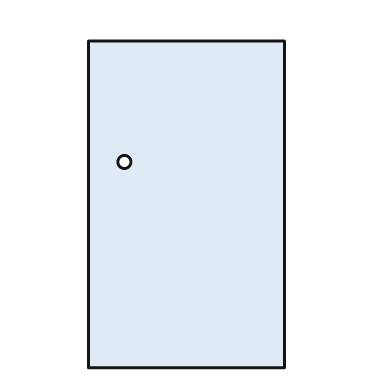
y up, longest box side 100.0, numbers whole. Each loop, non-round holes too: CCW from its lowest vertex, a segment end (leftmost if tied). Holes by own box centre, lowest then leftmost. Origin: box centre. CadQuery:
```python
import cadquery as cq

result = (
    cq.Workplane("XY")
    .moveTo(-30.0, -50.0)
    .lineTo(30.0, -50.0)
    .lineTo(30.0, 50.0)
    .lineTo(-30.0, 50.0)
    .close()
    .moveTo(-19.0, 13.0)
    .circle(2.0)
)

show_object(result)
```